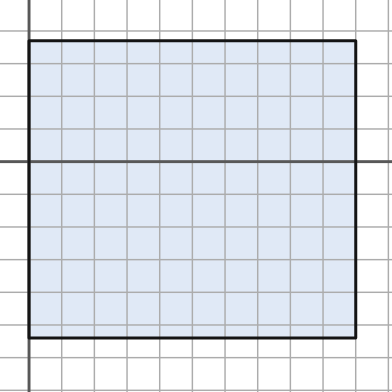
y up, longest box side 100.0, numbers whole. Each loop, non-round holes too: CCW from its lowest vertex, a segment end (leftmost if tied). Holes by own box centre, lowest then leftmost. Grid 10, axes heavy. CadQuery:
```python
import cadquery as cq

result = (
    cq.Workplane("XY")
    .moveTo(0.0, -54.0)
    .lineTo(100.0, -54.0)
    .lineTo(100.0, 37.0)
    .lineTo(0.0, 37.0)
    .close()
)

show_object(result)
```